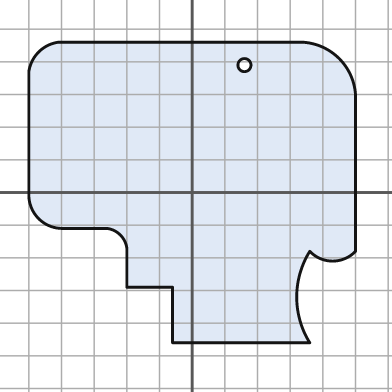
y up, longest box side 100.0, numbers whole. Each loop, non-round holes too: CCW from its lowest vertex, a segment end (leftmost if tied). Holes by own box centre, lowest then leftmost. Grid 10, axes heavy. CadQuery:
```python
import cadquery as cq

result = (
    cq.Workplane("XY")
    .moveTo(-6.0, -46.0)
    .lineTo(36.0, -46.0)
    .threePointArc((32.0, -32.0), (36.0, -18.0))
    .threePointArc((43.0, -21.0), (50.0, -18.0))
    .lineTo(50.0, 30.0)
    .threePointArc((45.0, 41.0), (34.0, 46.0))
    .lineTo(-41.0, 46.0)
    .threePointArc((-47.0, 43.0), (-50.0, 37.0))
    .lineTo(-50.0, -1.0)
    .threePointArc((-47.0, -8.0), (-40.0, -11.0))
    .lineTo(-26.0, -11.0)
    .threePointArc((-22.0, -13.0), (-20.0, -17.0))
    .lineTo(-20.0, -29.0)
    .lineTo(-6.0, -29.0)
    .close()
    .moveTo(16.0, 39.0)
    .circle(2.0)
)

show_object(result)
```